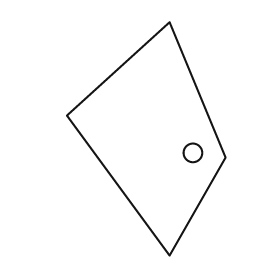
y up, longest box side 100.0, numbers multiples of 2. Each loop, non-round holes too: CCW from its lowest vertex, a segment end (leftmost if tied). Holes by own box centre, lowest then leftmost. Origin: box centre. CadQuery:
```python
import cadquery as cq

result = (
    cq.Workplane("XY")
    .moveTo(10.0, -50.0)
    .lineTo(34.0, -8.0)
    .lineTo(10.0, 50.0)
    .lineTo(-34.0, 10.0)
    .close()
    .moveTo(20.0, -6.0)
    .circle(4.0)
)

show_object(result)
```